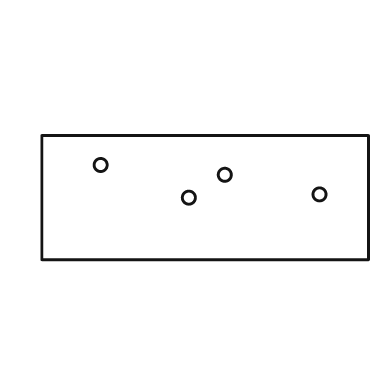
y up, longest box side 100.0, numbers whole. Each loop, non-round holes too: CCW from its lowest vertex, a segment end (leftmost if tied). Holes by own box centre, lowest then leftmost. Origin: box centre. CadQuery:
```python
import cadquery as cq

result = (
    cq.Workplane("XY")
    .moveTo(-50.0, -19.0)
    .lineTo(50.0, -19.0)
    .lineTo(50.0, 19.0)
    .lineTo(-50.0, 19.0)
    .close()
    .moveTo(-5.0, 0.0)
    .circle(2.0)
    .moveTo(35.0, 1.0)
    .circle(2.0)
    .moveTo(6.0, 7.0)
    .circle(2.0)
    .moveTo(-32.0, 10.0)
    .circle(2.0)
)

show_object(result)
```